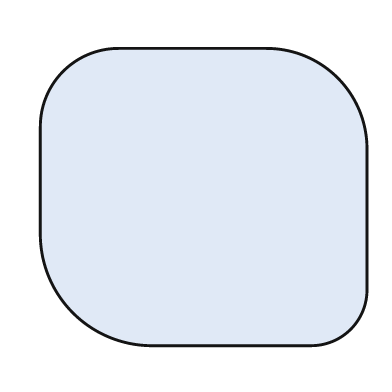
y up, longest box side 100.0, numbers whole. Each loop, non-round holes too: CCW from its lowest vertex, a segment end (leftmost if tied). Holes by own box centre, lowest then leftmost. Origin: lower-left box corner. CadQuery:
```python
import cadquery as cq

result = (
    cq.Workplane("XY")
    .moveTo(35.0, 0.0)
    .lineTo(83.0, 0.0)
    .threePointArc((95.0, 5.0), (100.0, 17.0))
    .lineTo(100.0, 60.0)
    .threePointArc((91.0, 82.0), (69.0, 91.0))
    .lineTo(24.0, 91.0)
    .threePointArc((7.0, 84.0), (0.0, 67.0))
    .lineTo(0.0, 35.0)
    .threePointArc((10.0, 10.0), (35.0, 0.0))
    .close()
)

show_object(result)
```